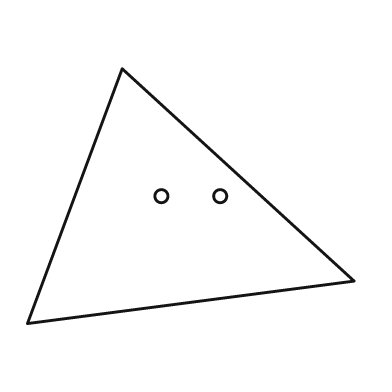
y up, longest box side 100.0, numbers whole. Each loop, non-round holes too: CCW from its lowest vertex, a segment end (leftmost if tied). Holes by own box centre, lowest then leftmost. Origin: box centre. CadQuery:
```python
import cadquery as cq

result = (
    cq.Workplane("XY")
    .moveTo(-50.0, -39.0)
    .lineTo(50.0, -26.0)
    .lineTo(-21.0, 39.0)
    .close()
    .moveTo(-9.0, 0.0)
    .circle(2.0)
    .moveTo(9.0, 0.0)
    .circle(2.0)
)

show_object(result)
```